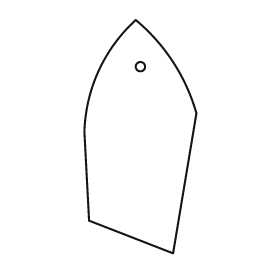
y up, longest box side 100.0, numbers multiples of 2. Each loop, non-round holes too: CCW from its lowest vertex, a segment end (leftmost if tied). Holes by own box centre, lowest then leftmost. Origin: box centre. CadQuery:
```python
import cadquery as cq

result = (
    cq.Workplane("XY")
    .moveTo(14.0, -50.0)
    .lineTo(24.0, 10.0)
    .threePointArc((14.0, 32.0), (-2.0, 50.0))
    .threePointArc((-18.0, 28.0), (-24.0, 2.0))
    .lineTo(-22.0, -36.0)
    .close()
    .moveTo(0.0, 30.0)
    .circle(2.0)
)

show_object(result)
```